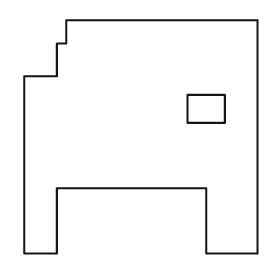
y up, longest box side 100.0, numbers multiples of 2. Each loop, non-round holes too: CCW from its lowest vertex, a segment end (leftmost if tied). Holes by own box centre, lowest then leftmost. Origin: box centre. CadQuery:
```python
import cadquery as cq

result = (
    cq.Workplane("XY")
    .moveTo(-50.0, -50.0)
    .lineTo(-36.0, -50.0)
    .lineTo(-36.0, -22.0)
    .lineTo(28.0, -22.0)
    .lineTo(28.0, -50.0)
    .lineTo(50.0, -50.0)
    .lineTo(50.0, 50.0)
    .lineTo(-32.0, 50.0)
    .lineTo(-32.0, 40.0)
    .lineTo(-36.0, 40.0)
    .lineTo(-36.0, 26.0)
    .lineTo(-50.0, 26.0)
    .close()
    .moveTo(20.0, 6.0)
    .lineTo(36.0, 6.0)
    .lineTo(36.0, 18.0)
    .lineTo(20.0, 18.0)
    .close()
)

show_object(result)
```